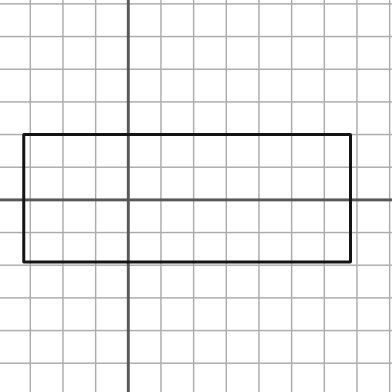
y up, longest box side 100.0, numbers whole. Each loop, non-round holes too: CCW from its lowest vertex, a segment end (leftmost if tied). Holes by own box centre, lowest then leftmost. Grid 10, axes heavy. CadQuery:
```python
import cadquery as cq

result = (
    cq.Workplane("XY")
    .moveTo(-32.0, -19.0)
    .lineTo(68.0, -19.0)
    .lineTo(68.0, 20.0)
    .lineTo(-32.0, 20.0)
    .close()
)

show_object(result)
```